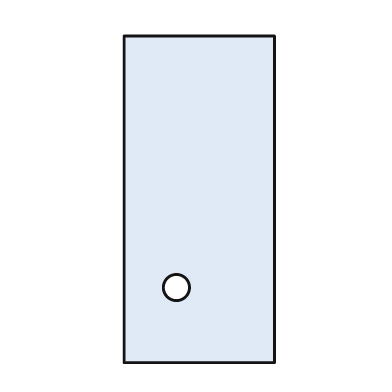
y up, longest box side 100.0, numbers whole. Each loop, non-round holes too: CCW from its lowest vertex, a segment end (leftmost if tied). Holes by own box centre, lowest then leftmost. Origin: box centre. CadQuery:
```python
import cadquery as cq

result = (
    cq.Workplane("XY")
    .moveTo(-23.0, -50.0)
    .lineTo(23.0, -50.0)
    .lineTo(23.0, 50.0)
    .lineTo(-23.0, 50.0)
    .close()
    .moveTo(-7.0, -27.0)
    .circle(4.0)
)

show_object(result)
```